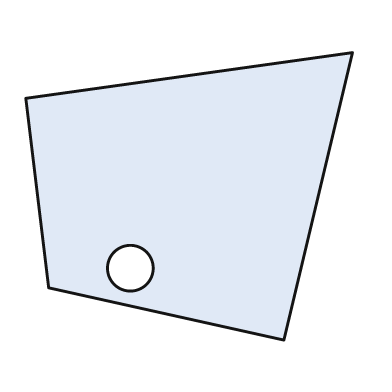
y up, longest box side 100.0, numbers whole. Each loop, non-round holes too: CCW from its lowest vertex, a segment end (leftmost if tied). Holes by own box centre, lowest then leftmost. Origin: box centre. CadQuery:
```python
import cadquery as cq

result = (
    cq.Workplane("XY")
    .moveTo(29.0, -44.0)
    .lineTo(50.0, 44.0)
    .lineTo(-50.0, 30.0)
    .lineTo(-43.0, -28.0)
    .close()
    .moveTo(-18.0, -22.0)
    .circle(7.0)
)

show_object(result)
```